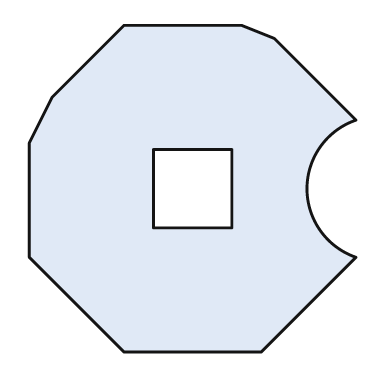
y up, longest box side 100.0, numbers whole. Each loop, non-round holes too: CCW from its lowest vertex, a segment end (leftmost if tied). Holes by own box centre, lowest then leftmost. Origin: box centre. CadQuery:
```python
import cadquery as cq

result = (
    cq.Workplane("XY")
    .moveTo(-21.0, -50.0)
    .lineTo(21.0, -50.0)
    .lineTo(50.0, -21.0)
    .threePointArc((35.0, 0.0), (50.0, 21.0))
    .lineTo(25.0, 46.0)
    .lineTo(15.0, 50.0)
    .lineTo(-21.0, 50.0)
    .lineTo(-43.0, 28.0)
    .lineTo(-50.0, 14.0)
    .lineTo(-50.0, -21.0)
    .close()
    .moveTo(-12.0, -12.0)
    .lineTo(12.0, -12.0)
    .lineTo(12.0, 12.0)
    .lineTo(-12.0, 12.0)
    .close()
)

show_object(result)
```